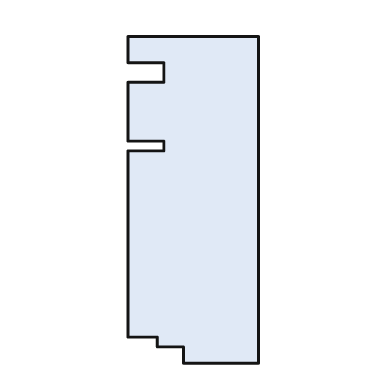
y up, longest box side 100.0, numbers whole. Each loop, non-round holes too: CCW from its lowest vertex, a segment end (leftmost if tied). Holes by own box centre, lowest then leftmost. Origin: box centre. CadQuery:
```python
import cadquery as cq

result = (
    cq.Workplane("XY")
    .moveTo(-3.0, -50.0)
    .lineTo(20.0, -50.0)
    .lineTo(20.0, 50.0)
    .lineTo(-20.0, 50.0)
    .lineTo(-20.0, 42.0)
    .lineTo(-9.0, 42.0)
    .lineTo(-9.0, 36.0)
    .lineTo(-20.0, 36.0)
    .lineTo(-20.0, 18.0)
    .lineTo(-9.0, 18.0)
    .lineTo(-9.0, 15.0)
    .lineTo(-20.0, 15.0)
    .lineTo(-20.0, -42.0)
    .lineTo(-11.0, -42.0)
    .lineTo(-11.0, -45.0)
    .lineTo(-3.0, -45.0)
    .close()
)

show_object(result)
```